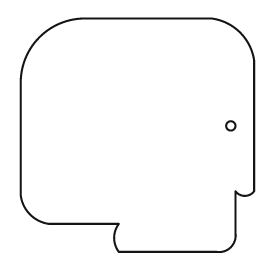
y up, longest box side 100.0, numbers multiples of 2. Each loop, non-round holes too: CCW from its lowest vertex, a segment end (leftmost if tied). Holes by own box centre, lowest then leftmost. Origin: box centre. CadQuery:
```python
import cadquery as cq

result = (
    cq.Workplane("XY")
    .moveTo(-8.0, -50.0)
    .lineTo(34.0, -50.0)
    .threePointArc((40.0, -48.0), (42.0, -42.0))
    .lineTo(42.0, -24.0)
    .threePointArc((46.0, -26.0), (50.0, -24.0))
    .lineTo(50.0, 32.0)
    .threePointArc((44.0, 44.0), (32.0, 50.0))
    .lineTo(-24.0, 50.0)
    .threePointArc((-42.0, 42.0), (-50.0, 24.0))
    .lineTo(-50.0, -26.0)
    .threePointArc((-46.0, -34.0), (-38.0, -38.0))
    .lineTo(-8.0, -38.0)
    .threePointArc((-10.0, -44.0), (-8.0, -50.0))
    .close()
    .moveTo(40.0, 4.0)
    .circle(2.0)
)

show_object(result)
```